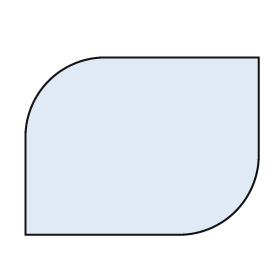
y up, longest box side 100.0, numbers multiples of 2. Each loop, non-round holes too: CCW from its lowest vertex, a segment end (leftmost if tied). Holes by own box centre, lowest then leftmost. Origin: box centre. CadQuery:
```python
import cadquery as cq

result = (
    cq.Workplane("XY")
    .moveTo(-50.0, -38.0)
    .lineTo(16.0, -38.0)
    .threePointArc((40.0, -28.0), (50.0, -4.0))
    .lineTo(50.0, 38.0)
    .lineTo(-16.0, 38.0)
    .threePointArc((-40.0, 28.0), (-50.0, 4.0))
    .close()
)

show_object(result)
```